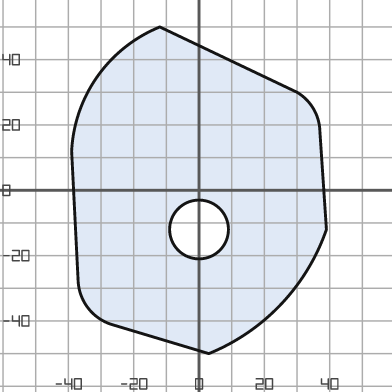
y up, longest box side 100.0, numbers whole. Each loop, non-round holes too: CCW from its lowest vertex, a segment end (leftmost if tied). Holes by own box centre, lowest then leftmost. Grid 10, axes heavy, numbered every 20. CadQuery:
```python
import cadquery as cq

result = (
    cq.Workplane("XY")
    .moveTo(3.0, -50.0)
    .threePointArc((25.0, -35.0), (39.0, -12.0))
    .lineTo(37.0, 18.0)
    .threePointArc((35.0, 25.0), (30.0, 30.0))
    .lineTo(-12.0, 50.0)
    .threePointArc((-31.0, 35.0), (-39.0, 12.0))
    .lineTo(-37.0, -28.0)
    .threePointArc((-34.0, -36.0), (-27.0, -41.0))
    .close()
    .moveTo(0.0, -12.0)
    .circle(9.0)
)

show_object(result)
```